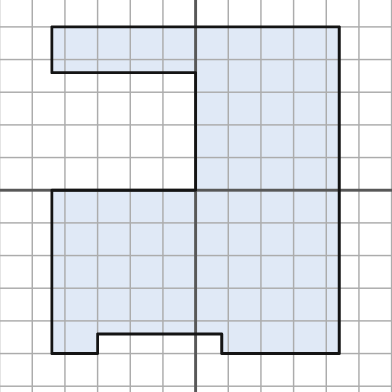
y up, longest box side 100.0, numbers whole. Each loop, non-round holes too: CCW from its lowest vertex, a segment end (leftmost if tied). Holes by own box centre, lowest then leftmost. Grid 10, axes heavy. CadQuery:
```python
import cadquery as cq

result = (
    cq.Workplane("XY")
    .moveTo(-44.0, -50.0)
    .lineTo(-30.0, -50.0)
    .lineTo(-30.0, -44.0)
    .lineTo(8.0, -44.0)
    .lineTo(8.0, -50.0)
    .lineTo(44.0, -50.0)
    .lineTo(44.0, 50.0)
    .lineTo(-44.0, 50.0)
    .lineTo(-44.0, 36.0)
    .lineTo(0.0, 36.0)
    .lineTo(0.0, 0.0)
    .lineTo(-44.0, 0.0)
    .close()
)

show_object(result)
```